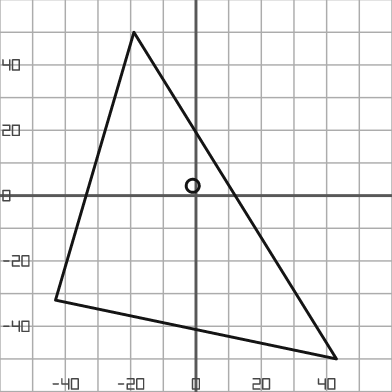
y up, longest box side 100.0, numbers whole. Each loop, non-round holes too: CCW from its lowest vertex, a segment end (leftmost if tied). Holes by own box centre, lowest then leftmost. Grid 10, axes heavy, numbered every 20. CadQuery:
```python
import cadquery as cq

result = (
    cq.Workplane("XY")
    .moveTo(43.0, -50.0)
    .lineTo(-19.0, 50.0)
    .lineTo(-43.0, -32.0)
    .close()
    .moveTo(-1.0, 3.0)
    .circle(2.0)
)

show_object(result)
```